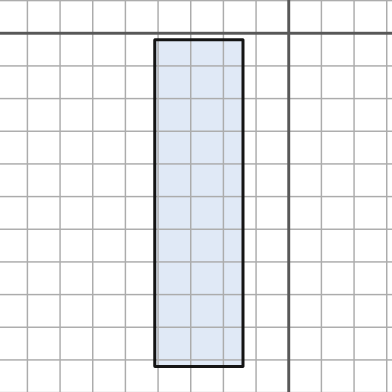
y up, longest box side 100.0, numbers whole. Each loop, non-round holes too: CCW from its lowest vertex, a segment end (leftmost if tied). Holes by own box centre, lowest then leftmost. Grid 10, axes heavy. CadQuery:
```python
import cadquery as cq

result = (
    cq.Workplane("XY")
    .moveTo(-41.0, -102.0)
    .lineTo(-14.0, -102.0)
    .lineTo(-14.0, -2.0)
    .lineTo(-41.0, -2.0)
    .close()
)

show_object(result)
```